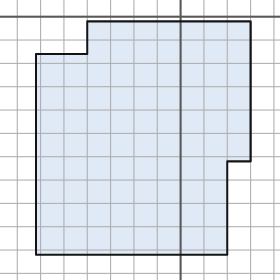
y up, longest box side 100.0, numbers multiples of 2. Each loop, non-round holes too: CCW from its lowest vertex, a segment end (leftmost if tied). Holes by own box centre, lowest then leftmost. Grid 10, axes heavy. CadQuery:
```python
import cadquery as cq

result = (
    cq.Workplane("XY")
    .moveTo(-62.0, -102.0)
    .lineTo(20.0, -102.0)
    .lineTo(20.0, -62.0)
    .lineTo(30.0, -62.0)
    .lineTo(30.0, -2.0)
    .lineTo(-40.0, -2.0)
    .lineTo(-40.0, -16.0)
    .lineTo(-62.0, -16.0)
    .close()
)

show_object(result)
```